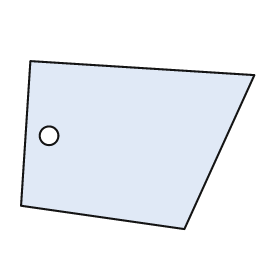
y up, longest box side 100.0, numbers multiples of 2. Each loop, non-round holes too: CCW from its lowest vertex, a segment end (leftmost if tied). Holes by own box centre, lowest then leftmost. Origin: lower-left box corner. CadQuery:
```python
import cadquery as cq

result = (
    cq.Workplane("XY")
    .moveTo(70.0, 0.0)
    .lineTo(100.0, 66.0)
    .lineTo(4.0, 72.0)
    .lineTo(0.0, 10.0)
    .close()
    .moveTo(12.0, 40.0)
    .circle(4.0)
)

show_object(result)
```